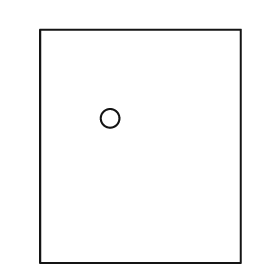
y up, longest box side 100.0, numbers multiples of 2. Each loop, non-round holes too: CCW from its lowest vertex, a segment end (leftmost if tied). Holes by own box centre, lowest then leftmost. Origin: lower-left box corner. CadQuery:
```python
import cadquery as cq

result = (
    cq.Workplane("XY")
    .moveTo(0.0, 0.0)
    .lineTo(86.0, 0.0)
    .lineTo(86.0, 100.0)
    .lineTo(0.0, 100.0)
    .close()
    .moveTo(30.0, 62.0)
    .circle(4.0)
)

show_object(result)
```